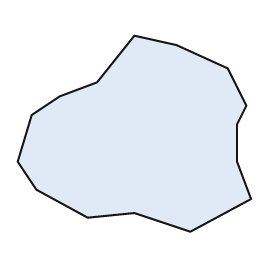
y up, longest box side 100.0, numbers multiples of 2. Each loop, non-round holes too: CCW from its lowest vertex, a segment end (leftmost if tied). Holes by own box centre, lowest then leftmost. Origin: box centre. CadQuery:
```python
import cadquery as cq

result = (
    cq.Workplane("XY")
    .moveTo(24.0, -42.0)
    .lineTo(50.0, -28.0)
    .lineTo(44.0, -12.0)
    .lineTo(44.0, 4.0)
    .lineTo(48.0, 12.0)
    .lineTo(40.0, 28.0)
    .lineTo(18.0, 38.0)
    .lineTo(0.0, 42.0)
    .lineTo(-16.0, 22.0)
    .lineTo(-32.0, 16.0)
    .lineTo(-44.0, 8.0)
    .lineTo(-50.0, -12.0)
    .lineTo(-42.0, -24.0)
    .lineTo(-20.0, -36.0)
    .lineTo(0.0, -34.0)
    .close()
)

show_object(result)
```